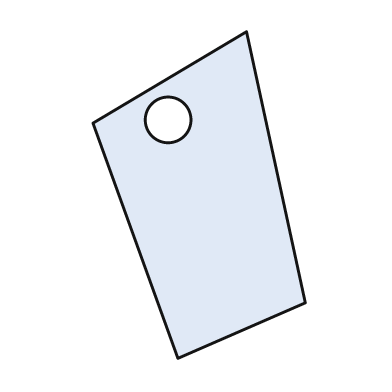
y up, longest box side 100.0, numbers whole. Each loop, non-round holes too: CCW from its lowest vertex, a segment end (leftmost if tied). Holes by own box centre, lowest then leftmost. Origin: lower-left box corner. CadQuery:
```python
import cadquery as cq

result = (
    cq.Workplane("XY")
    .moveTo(26.0, 0.0)
    .lineTo(65.0, 17.0)
    .lineTo(47.0, 100.0)
    .lineTo(0.0, 72.0)
    .close()
    .moveTo(23.0, 73.0)
    .circle(7.0)
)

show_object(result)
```